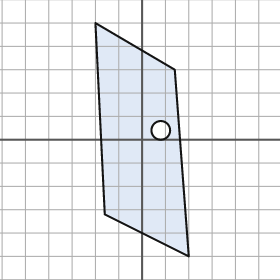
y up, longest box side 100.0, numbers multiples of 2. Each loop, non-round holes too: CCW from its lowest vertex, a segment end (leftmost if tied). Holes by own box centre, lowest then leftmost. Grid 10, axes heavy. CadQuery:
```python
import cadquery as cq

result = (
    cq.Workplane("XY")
    .moveTo(20.0, -50.0)
    .lineTo(14.0, 30.0)
    .lineTo(-20.0, 50.0)
    .lineTo(-16.0, -32.0)
    .close()
    .moveTo(8.0, 4.0)
    .circle(4.0)
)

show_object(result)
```